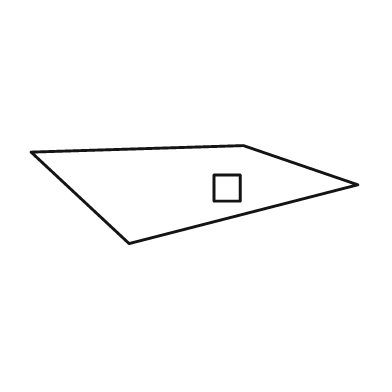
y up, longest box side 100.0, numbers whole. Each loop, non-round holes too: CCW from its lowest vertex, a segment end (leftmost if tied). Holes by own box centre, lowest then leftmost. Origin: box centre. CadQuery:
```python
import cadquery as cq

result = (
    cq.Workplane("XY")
    .moveTo(-20.0, -15.0)
    .lineTo(50.0, 3.0)
    .lineTo(15.0, 15.0)
    .lineTo(-50.0, 13.0)
    .close()
    .moveTo(6.0, -2.0)
    .lineTo(14.0, -2.0)
    .lineTo(14.0, 6.0)
    .lineTo(6.0, 6.0)
    .close()
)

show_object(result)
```